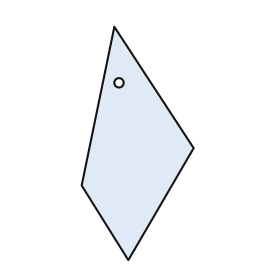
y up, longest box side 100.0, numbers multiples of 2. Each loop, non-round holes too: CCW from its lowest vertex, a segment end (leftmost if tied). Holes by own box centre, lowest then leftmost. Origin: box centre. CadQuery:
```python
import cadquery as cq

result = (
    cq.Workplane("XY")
    .moveTo(-4.0, -50.0)
    .lineTo(24.0, -2.0)
    .lineTo(-10.0, 50.0)
    .lineTo(-24.0, -18.0)
    .close()
    .moveTo(-8.0, 26.0)
    .circle(2.0)
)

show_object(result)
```